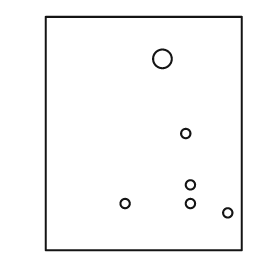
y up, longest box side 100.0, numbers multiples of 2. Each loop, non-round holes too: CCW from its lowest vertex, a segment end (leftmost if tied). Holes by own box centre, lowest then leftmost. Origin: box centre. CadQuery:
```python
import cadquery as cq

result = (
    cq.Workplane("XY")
    .moveTo(-42.0, -50.0)
    .lineTo(42.0, -50.0)
    .lineTo(42.0, 50.0)
    .lineTo(-42.0, 50.0)
    .close()
    .moveTo(36.0, -34.0)
    .circle(2.0)
    .moveTo(-8.0, -30.0)
    .circle(2.0)
    .moveTo(20.0, -30.0)
    .circle(2.0)
    .moveTo(20.0, -22.0)
    .circle(2.0)
    .moveTo(18.0, 0.0)
    .circle(2.0)
    .moveTo(8.0, 32.0)
    .circle(4.0)
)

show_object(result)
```